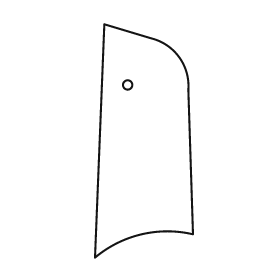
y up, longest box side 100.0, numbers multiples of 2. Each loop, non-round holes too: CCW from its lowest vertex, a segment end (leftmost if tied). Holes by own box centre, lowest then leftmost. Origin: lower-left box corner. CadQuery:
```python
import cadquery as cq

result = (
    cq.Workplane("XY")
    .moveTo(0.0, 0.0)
    .threePointArc((20.0, 10.0), (42.0, 10.0))
    .lineTo(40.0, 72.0)
    .threePointArc((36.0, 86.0), (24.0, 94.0))
    .lineTo(4.0, 100.0)
    .close()
    .moveTo(14.0, 74.0)
    .circle(2.0)
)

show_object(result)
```